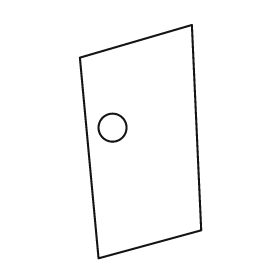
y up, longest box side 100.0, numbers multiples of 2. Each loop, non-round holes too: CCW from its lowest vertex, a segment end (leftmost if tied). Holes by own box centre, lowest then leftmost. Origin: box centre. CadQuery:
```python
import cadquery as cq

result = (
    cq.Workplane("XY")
    .moveTo(-18.0, -50.0)
    .lineTo(26.0, -38.0)
    .lineTo(22.0, 50.0)
    .lineTo(-26.0, 36.0)
    .close()
    .moveTo(-12.0, 6.0)
    .circle(6.0)
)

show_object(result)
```